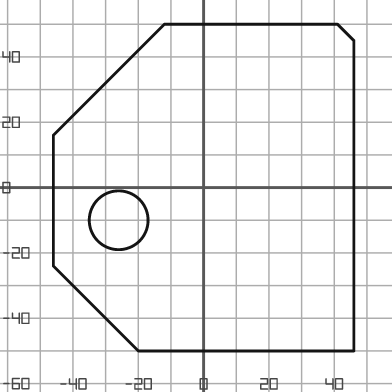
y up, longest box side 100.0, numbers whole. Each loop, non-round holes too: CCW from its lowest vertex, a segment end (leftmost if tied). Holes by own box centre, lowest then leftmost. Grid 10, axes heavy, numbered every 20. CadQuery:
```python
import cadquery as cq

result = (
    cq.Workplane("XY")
    .moveTo(-20.0, -50.0)
    .lineTo(46.0, -50.0)
    .lineTo(46.0, 45.0)
    .lineTo(41.0, 50.0)
    .lineTo(-12.0, 50.0)
    .lineTo(-46.0, 16.0)
    .lineTo(-46.0, -24.0)
    .close()
    .moveTo(-26.0, -10.0)
    .circle(9.0)
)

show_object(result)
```